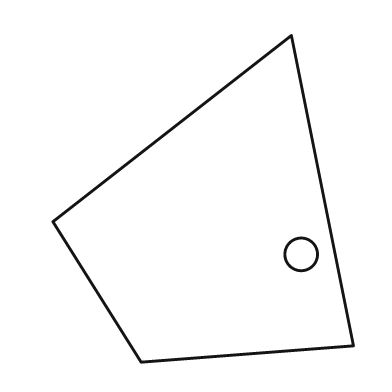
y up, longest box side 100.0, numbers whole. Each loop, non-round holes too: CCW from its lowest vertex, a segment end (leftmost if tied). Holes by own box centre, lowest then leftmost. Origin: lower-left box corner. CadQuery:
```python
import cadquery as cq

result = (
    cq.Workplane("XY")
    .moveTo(27.0, 0.0)
    .lineTo(92.0, 5.0)
    .lineTo(73.0, 100.0)
    .lineTo(0.0, 43.0)
    .close()
    .moveTo(76.0, 33.0)
    .circle(5.0)
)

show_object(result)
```